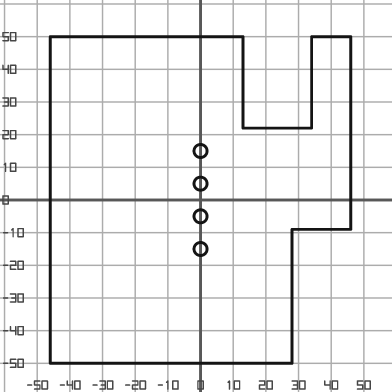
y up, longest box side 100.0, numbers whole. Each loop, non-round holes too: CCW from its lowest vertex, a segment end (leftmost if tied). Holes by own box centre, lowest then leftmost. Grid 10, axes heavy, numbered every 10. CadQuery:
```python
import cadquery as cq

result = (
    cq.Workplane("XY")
    .moveTo(-46.0, -50.0)
    .lineTo(28.0, -50.0)
    .lineTo(28.0, -9.0)
    .lineTo(46.0, -9.0)
    .lineTo(46.0, 50.0)
    .lineTo(34.0, 50.0)
    .lineTo(34.0, 22.0)
    .lineTo(13.0, 22.0)
    .lineTo(13.0, 50.0)
    .lineTo(-46.0, 50.0)
    .close()
    .moveTo(0.0, -15.0)
    .circle(2.0)
    .moveTo(0.0, -5.0)
    .circle(2.0)
    .moveTo(0.0, 5.0)
    .circle(2.0)
    .moveTo(0.0, 15.0)
    .circle(2.0)
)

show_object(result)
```